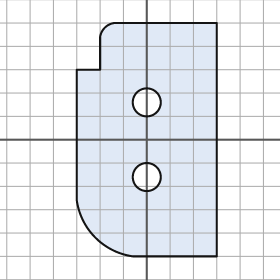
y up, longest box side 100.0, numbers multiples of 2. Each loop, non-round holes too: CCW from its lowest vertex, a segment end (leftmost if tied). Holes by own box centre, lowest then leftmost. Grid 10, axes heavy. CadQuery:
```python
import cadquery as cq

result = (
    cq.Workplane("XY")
    .moveTo(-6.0, -50.0)
    .lineTo(30.0, -50.0)
    .lineTo(30.0, 50.0)
    .lineTo(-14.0, 50.0)
    .threePointArc((-18.0, 48.0), (-20.0, 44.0))
    .lineTo(-20.0, 30.0)
    .lineTo(-30.0, 30.0)
    .lineTo(-30.0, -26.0)
    .threePointArc((-22.0, -42.0), (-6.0, -50.0))
    .close()
    .moveTo(0.0, -16.0)
    .circle(6.0)
    .moveTo(0.0, 16.0)
    .circle(6.0)
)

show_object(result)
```